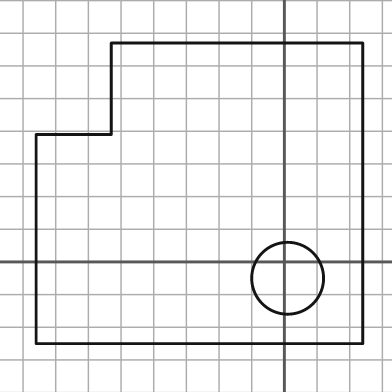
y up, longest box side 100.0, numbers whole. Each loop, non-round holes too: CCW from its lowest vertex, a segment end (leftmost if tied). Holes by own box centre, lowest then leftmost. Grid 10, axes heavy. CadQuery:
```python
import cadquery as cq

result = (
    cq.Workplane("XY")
    .moveTo(-76.0, -25.0)
    .lineTo(24.0, -25.0)
    .lineTo(24.0, 67.0)
    .lineTo(-53.0, 67.0)
    .lineTo(-53.0, 39.0)
    .lineTo(-76.0, 39.0)
    .close()
    .moveTo(1.0, -5.0)
    .circle(11.0)
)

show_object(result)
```